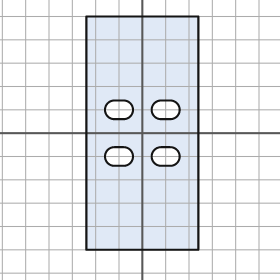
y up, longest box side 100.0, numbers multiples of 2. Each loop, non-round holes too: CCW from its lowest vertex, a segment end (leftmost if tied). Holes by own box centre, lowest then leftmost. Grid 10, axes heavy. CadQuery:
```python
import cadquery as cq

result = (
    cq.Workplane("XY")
    .moveTo(-24.0, -50.0)
    .lineTo(24.0, -50.0)
    .lineTo(24.0, 50.0)
    .lineTo(-24.0, 50.0)
    .close()
    .moveTo(-12.0, -14.0)
    .lineTo(-8.0, -14.0)
    .threePointArc((-4.0, -10.0), (-8.0, -6.0))
    .lineTo(-12.0, -6.0)
    .threePointArc((-16.0, -10.0), (-12.0, -14.0))
    .close()
    .moveTo(8.0, -14.0)
    .lineTo(12.0, -14.0)
    .threePointArc((16.0, -10.0), (12.0, -6.0))
    .lineTo(8.0, -6.0)
    .threePointArc((4.0, -10.0), (8.0, -14.0))
    .close()
    .moveTo(-12.0, 6.0)
    .lineTo(-8.0, 6.0)
    .threePointArc((-4.0, 10.0), (-8.0, 14.0))
    .lineTo(-12.0, 14.0)
    .threePointArc((-16.0, 10.0), (-12.0, 6.0))
    .close()
    .moveTo(8.0, 6.0)
    .lineTo(12.0, 6.0)
    .threePointArc((16.0, 10.0), (12.0, 14.0))
    .lineTo(8.0, 14.0)
    .threePointArc((4.0, 10.0), (8.0, 6.0))
    .close()
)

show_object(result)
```